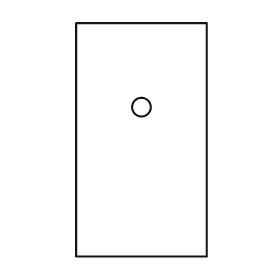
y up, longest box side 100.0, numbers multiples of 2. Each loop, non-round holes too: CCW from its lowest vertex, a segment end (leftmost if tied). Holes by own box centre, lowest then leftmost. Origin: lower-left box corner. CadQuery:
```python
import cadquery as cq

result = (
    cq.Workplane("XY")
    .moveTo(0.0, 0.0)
    .lineTo(56.0, 0.0)
    .lineTo(56.0, 100.0)
    .lineTo(0.0, 100.0)
    .close()
    .moveTo(28.0, 64.0)
    .circle(4.0)
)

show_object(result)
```